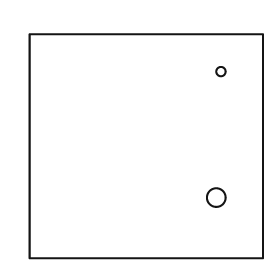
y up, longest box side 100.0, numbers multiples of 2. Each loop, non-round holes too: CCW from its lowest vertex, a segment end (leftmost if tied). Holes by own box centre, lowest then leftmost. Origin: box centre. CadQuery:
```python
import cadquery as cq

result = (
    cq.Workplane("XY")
    .moveTo(-50.0, -48.0)
    .lineTo(50.0, -48.0)
    .lineTo(50.0, 48.0)
    .lineTo(-50.0, 48.0)
    .close()
    .moveTo(30.0, -22.0)
    .circle(4.0)
    .moveTo(32.0, 32.0)
    .circle(2.0)
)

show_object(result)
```